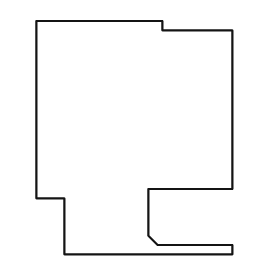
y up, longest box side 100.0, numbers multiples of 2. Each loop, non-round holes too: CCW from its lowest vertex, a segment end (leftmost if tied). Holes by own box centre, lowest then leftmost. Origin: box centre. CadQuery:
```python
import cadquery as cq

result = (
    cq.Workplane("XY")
    .moveTo(-30.0, -50.0)
    .lineTo(42.0, -50.0)
    .lineTo(42.0, -46.0)
    .lineTo(10.0, -46.0)
    .lineTo(6.0, -42.0)
    .lineTo(6.0, -22.0)
    .lineTo(42.0, -22.0)
    .lineTo(42.0, 46.0)
    .lineTo(12.0, 46.0)
    .lineTo(12.0, 50.0)
    .lineTo(-42.0, 50.0)
    .lineTo(-42.0, -26.0)
    .lineTo(-30.0, -26.0)
    .close()
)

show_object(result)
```